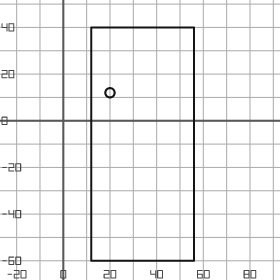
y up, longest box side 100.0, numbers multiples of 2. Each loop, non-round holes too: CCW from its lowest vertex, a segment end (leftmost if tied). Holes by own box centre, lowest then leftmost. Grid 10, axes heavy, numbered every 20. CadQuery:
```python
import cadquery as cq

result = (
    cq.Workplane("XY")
    .moveTo(12.0, -60.0)
    .lineTo(56.0, -60.0)
    .lineTo(56.0, 40.0)
    .lineTo(12.0, 40.0)
    .close()
    .moveTo(20.0, 12.0)
    .circle(2.0)
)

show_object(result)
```